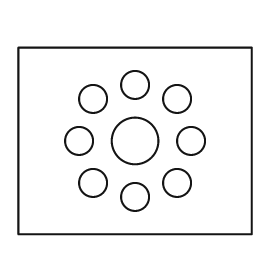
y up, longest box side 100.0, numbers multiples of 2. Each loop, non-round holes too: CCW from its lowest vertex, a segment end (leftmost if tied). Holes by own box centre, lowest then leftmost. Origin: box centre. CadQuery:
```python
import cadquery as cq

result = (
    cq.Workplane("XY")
    .moveTo(-50.0, -40.0)
    .lineTo(50.0, -40.0)
    .lineTo(50.0, 40.0)
    .lineTo(-50.0, 40.0)
    .close()
    .moveTo(0.0, -24.0)
    .circle(6.0)
    .moveTo(-18.0, -18.0)
    .circle(6.0)
    .moveTo(18.0, -18.0)
    .circle(6.0)
    .moveTo(-24.0, 0.0)
    .circle(6.0)
    .moveTo(0.0, 0.0)
    .circle(10.0)
    .moveTo(24.0, 0.0)
    .circle(6.0)
    .moveTo(-18.0, 18.0)
    .circle(6.0)
    .moveTo(18.0, 18.0)
    .circle(6.0)
    .moveTo(0.0, 24.0)
    .circle(6.0)
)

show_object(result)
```